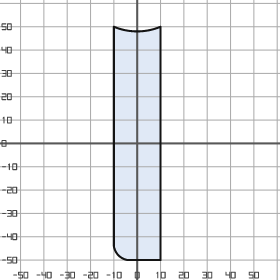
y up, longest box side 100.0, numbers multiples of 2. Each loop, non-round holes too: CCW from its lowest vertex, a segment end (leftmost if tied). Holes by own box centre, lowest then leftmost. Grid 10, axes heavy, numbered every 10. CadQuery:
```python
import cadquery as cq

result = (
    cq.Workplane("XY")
    .moveTo(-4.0, -50.0)
    .lineTo(10.0, -50.0)
    .lineTo(10.0, 50.0)
    .threePointArc((0.0, 48.0), (-10.0, 50.0))
    .lineTo(-10.0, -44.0)
    .threePointArc((-8.0, -48.0), (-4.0, -50.0))
    .close()
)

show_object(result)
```